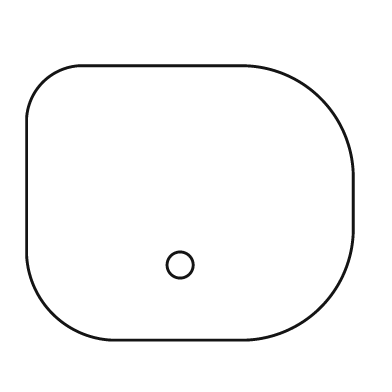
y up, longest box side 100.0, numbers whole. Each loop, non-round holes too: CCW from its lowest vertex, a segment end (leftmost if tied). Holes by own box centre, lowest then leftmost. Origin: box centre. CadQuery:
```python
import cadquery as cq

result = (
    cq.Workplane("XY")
    .moveTo(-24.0, -42.0)
    .lineTo(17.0, -42.0)
    .threePointArc((40.0, -32.0), (50.0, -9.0))
    .lineTo(50.0, 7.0)
    .threePointArc((40.0, 32.0), (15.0, 42.0))
    .lineTo(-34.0, 42.0)
    .threePointArc((-45.0, 37.0), (-50.0, 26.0))
    .lineTo(-50.0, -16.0)
    .threePointArc((-42.0, -34.0), (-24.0, -42.0))
    .close()
    .moveTo(-3.0, -19.0)
    .circle(4.0)
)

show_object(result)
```